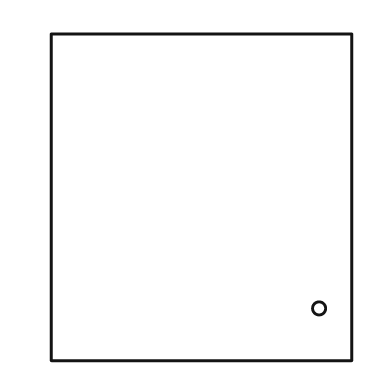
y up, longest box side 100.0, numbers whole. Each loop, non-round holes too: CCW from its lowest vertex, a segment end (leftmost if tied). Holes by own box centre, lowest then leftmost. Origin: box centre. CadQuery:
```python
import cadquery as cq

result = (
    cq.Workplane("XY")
    .moveTo(-46.0, -50.0)
    .lineTo(46.0, -50.0)
    .lineTo(46.0, 50.0)
    .lineTo(-46.0, 50.0)
    .close()
    .moveTo(36.0, -34.0)
    .circle(2.0)
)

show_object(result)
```